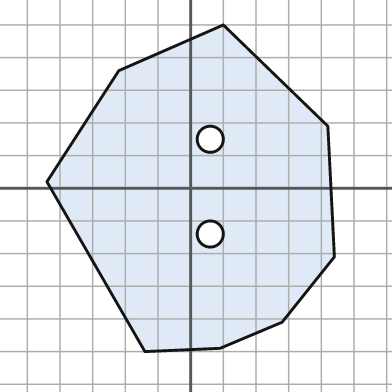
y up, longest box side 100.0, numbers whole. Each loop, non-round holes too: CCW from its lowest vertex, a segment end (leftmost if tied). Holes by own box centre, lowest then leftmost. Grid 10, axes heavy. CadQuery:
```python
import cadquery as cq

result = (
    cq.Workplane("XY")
    .moveTo(-14.0, -50.0)
    .lineTo(9.0, -49.0)
    .lineTo(28.0, -41.0)
    .lineTo(44.0, -21.0)
    .lineTo(42.0, 19.0)
    .lineTo(10.0, 50.0)
    .lineTo(-22.0, 36.0)
    .lineTo(-44.0, 2.0)
    .close()
    .moveTo(6.0, -14.0)
    .circle(4.0)
    .moveTo(6.0, 15.0)
    .circle(4.0)
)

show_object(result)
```